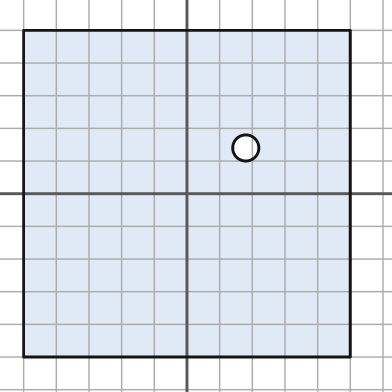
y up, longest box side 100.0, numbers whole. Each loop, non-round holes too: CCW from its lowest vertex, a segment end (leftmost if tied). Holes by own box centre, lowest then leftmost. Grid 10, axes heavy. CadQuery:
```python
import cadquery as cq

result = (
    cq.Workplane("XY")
    .moveTo(-50.0, -50.0)
    .lineTo(50.0, -50.0)
    .lineTo(50.0, 50.0)
    .lineTo(-50.0, 50.0)
    .close()
    .moveTo(18.0, 14.0)
    .circle(4.0)
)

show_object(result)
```